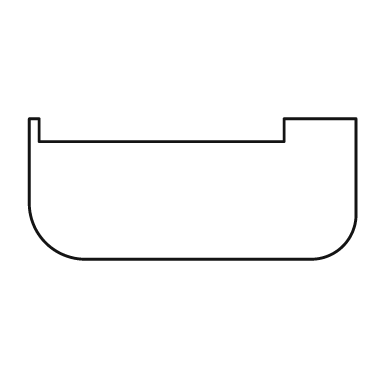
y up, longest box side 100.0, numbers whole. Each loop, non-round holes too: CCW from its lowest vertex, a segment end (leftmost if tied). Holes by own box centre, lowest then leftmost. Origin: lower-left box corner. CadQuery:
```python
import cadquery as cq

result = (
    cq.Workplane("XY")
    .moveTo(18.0, 0.0)
    .lineTo(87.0, 0.0)
    .threePointArc((96.0, 4.0), (100.0, 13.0))
    .lineTo(100.0, 43.0)
    .lineTo(78.0, 43.0)
    .lineTo(78.0, 36.0)
    .lineTo(3.0, 36.0)
    .lineTo(3.0, 43.0)
    .lineTo(0.0, 43.0)
    .lineTo(0.0, 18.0)
    .threePointArc((5.0, 5.0), (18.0, 0.0))
    .close()
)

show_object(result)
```